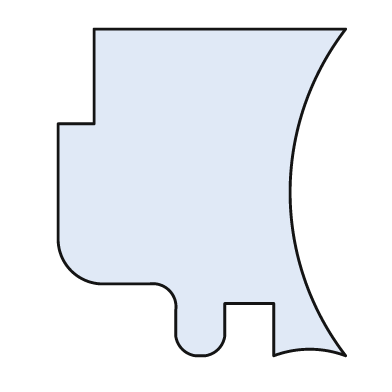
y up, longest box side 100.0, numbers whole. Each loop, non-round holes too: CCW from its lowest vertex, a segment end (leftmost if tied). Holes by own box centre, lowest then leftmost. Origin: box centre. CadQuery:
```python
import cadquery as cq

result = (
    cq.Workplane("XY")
    .moveTo(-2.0, -50.0)
    .lineTo(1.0, -50.0)
    .threePointArc((5.0, -48.0), (7.0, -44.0))
    .lineTo(7.0, -34.0)
    .lineTo(22.0, -34.0)
    .lineTo(22.0, -50.0)
    .threePointArc((33.0, -48.0), (44.0, -50.0))
    .threePointArc((27.0, 0.0), (44.0, 50.0))
    .lineTo(-33.0, 50.0)
    .lineTo(-33.0, 21.0)
    .lineTo(-44.0, 21.0)
    .lineTo(-44.0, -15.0)
    .threePointArc((-40.0, -24.0), (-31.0, -28.0))
    .lineTo(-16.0, -28.0)
    .threePointArc((-10.0, -30.0), (-8.0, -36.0))
    .lineTo(-8.0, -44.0)
    .threePointArc((-6.0, -48.0), (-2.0, -50.0))
    .close()
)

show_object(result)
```